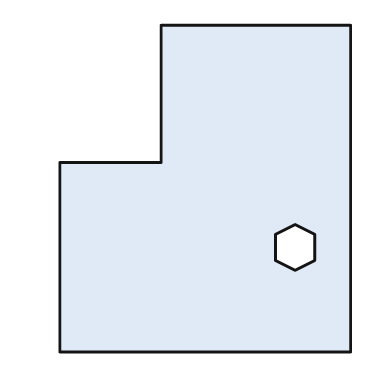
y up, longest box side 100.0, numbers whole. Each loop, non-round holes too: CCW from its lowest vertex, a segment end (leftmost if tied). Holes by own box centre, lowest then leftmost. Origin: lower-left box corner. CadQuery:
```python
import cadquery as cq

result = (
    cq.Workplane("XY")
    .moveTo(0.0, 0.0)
    .lineTo(89.0, 0.0)
    .lineTo(89.0, 100.0)
    .lineTo(31.0, 100.0)
    .lineTo(31.0, 58.0)
    .lineTo(0.0, 58.0)
    .close()
    .moveTo(72.0, 25.0)
    .lineTo(78.0, 28.0)
    .lineTo(78.0, 36.0)
    .lineTo(72.0, 39.0)
    .lineTo(66.0, 36.0)
    .lineTo(66.0, 28.0)
    .close()
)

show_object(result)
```